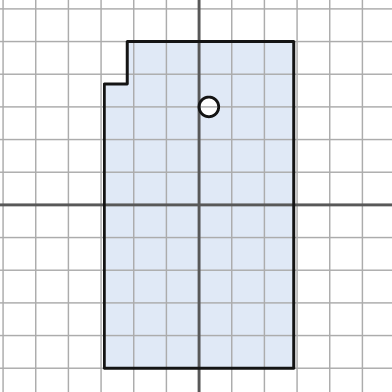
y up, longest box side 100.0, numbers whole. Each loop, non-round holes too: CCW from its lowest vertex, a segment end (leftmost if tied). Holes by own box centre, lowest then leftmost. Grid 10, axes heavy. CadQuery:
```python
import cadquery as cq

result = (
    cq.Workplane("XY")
    .moveTo(-29.0, -50.0)
    .lineTo(29.0, -50.0)
    .lineTo(29.0, 50.0)
    .lineTo(-22.0, 50.0)
    .lineTo(-22.0, 37.0)
    .lineTo(-29.0, 37.0)
    .close()
    .moveTo(3.0, 30.0)
    .circle(3.0)
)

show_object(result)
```